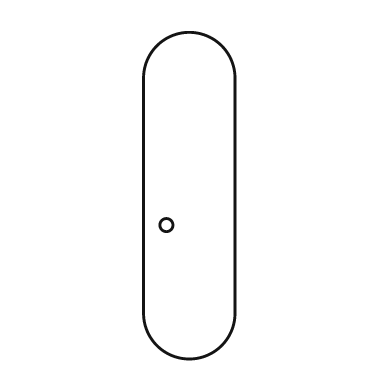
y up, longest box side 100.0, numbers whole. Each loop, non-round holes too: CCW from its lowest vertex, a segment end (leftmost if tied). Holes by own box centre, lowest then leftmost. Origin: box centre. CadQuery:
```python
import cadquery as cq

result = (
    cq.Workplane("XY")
    .moveTo(-14.0, -36.0)
    .threePointArc((0.0, -50.0), (14.0, -36.0))
    .lineTo(14.0, 36.0)
    .threePointArc((0.0, 50.0), (-14.0, 36.0))
    .close()
    .moveTo(-7.0, -9.0)
    .circle(2.0)
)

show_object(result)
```